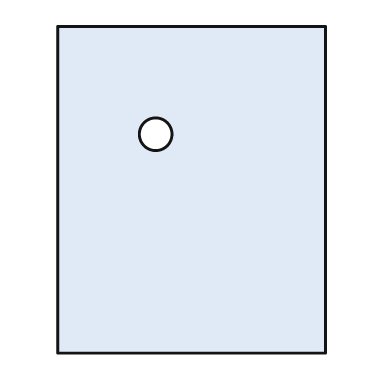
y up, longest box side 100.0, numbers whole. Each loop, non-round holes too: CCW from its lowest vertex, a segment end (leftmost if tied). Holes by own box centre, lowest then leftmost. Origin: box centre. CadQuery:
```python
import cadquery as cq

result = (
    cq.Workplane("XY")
    .moveTo(-41.0, -50.0)
    .lineTo(41.0, -50.0)
    .lineTo(41.0, 50.0)
    .lineTo(-41.0, 50.0)
    .close()
    .moveTo(-11.0, 17.0)
    .circle(5.0)
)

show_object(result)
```